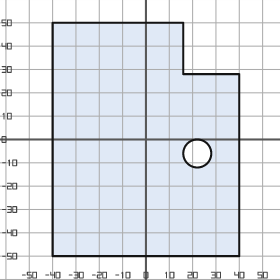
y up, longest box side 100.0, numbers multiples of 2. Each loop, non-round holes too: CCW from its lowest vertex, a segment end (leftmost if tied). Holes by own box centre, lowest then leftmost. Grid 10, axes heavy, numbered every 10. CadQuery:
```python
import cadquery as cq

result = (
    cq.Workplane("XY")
    .moveTo(-40.0, -50.0)
    .lineTo(40.0, -50.0)
    .lineTo(40.0, 28.0)
    .lineTo(16.0, 28.0)
    .lineTo(16.0, 50.0)
    .lineTo(-40.0, 50.0)
    .close()
    .moveTo(22.0, -6.0)
    .circle(6.0)
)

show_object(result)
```